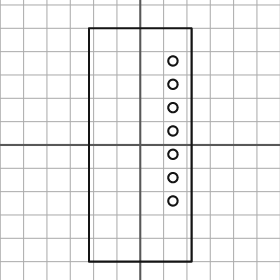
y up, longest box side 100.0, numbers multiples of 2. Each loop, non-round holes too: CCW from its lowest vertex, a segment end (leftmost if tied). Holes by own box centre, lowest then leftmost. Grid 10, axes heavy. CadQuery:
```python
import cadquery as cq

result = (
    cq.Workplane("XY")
    .moveTo(-22.0, -50.0)
    .lineTo(22.0, -50.0)
    .lineTo(22.0, 50.0)
    .lineTo(-22.0, 50.0)
    .close()
    .moveTo(14.0, -24.0)
    .circle(2.0)
    .moveTo(14.0, -14.0)
    .circle(2.0)
    .moveTo(14.0, -4.0)
    .circle(2.0)
    .moveTo(14.0, 6.0)
    .circle(2.0)
    .moveTo(14.0, 16.0)
    .circle(2.0)
    .moveTo(14.0, 26.0)
    .circle(2.0)
    .moveTo(14.0, 36.0)
    .circle(2.0)
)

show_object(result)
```